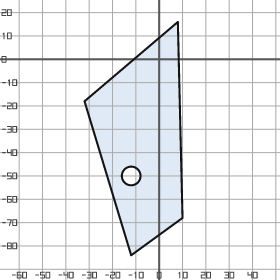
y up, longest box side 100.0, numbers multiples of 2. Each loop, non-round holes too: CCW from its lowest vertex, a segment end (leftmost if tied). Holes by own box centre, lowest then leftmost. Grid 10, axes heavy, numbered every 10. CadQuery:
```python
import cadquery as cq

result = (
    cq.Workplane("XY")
    .moveTo(-12.0, -84.0)
    .lineTo(10.0, -68.0)
    .lineTo(8.0, 16.0)
    .lineTo(-32.0, -18.0)
    .close()
    .moveTo(-12.0, -50.0)
    .circle(4.0)
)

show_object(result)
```